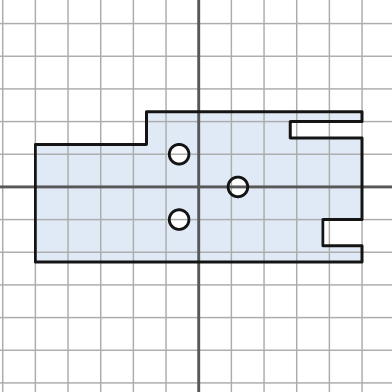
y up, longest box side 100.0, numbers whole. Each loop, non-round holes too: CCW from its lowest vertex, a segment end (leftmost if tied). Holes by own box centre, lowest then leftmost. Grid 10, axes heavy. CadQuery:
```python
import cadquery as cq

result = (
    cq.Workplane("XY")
    .moveTo(-50.0, -23.0)
    .lineTo(50.0, -23.0)
    .lineTo(50.0, -18.0)
    .lineTo(38.0, -18.0)
    .lineTo(38.0, -10.0)
    .lineTo(50.0, -10.0)
    .lineTo(50.0, 15.0)
    .lineTo(28.0, 15.0)
    .lineTo(28.0, 20.0)
    .lineTo(50.0, 20.0)
    .lineTo(50.0, 23.0)
    .lineTo(-16.0, 23.0)
    .lineTo(-16.0, 13.0)
    .lineTo(-50.0, 13.0)
    .close()
    .moveTo(-6.0, -10.0)
    .circle(3.0)
    .moveTo(12.0, 0.0)
    .circle(3.0)
    .moveTo(-6.0, 10.0)
    .circle(3.0)
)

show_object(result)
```